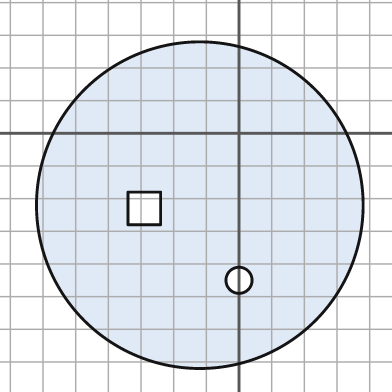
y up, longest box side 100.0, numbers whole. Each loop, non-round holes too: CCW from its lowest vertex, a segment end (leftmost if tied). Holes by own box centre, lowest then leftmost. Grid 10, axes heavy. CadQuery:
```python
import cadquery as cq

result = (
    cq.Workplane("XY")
    .moveTo(-12.0, -22.0)
    .circle(50.0)
    .moveTo(0.0, -45.0)
    .circle(4.0)
    .moveTo(-34.0, -28.0)
    .lineTo(-24.0, -28.0)
    .lineTo(-24.0, -18.0)
    .lineTo(-34.0, -18.0)
    .close()
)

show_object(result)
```